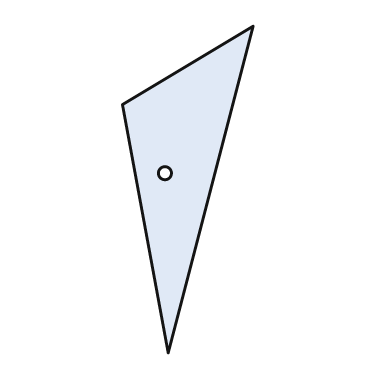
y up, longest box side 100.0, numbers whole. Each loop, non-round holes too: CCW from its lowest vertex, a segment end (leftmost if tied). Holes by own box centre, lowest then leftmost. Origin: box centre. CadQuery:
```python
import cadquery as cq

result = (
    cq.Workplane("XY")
    .moveTo(-6.0, -50.0)
    .lineTo(20.0, 50.0)
    .lineTo(-20.0, 26.0)
    .close()
    .moveTo(-7.0, 5.0)
    .circle(2.0)
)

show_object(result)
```